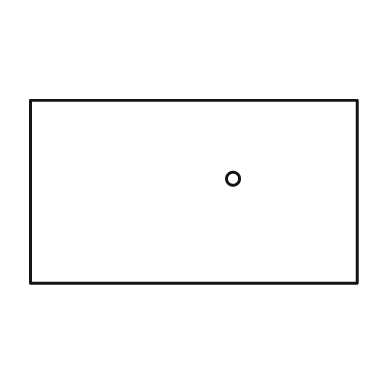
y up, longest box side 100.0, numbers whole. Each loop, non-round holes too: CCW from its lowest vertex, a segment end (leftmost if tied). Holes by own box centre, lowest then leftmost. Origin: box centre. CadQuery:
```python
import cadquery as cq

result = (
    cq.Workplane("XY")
    .moveTo(-50.0, -28.0)
    .lineTo(50.0, -28.0)
    .lineTo(50.0, 28.0)
    .lineTo(-50.0, 28.0)
    .close()
    .moveTo(12.0, 4.0)
    .circle(2.0)
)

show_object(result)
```